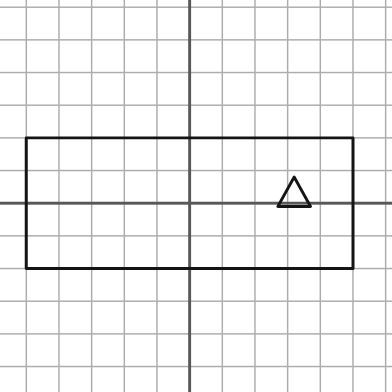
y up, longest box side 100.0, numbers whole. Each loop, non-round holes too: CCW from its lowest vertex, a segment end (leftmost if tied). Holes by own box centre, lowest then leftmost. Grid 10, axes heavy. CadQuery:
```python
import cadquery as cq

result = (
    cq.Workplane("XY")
    .moveTo(-50.0, -20.0)
    .lineTo(50.0, -20.0)
    .lineTo(50.0, 20.0)
    .lineTo(-50.0, 20.0)
    .close()
    .moveTo(27.0, -1.0)
    .lineTo(37.0, -1.0)
    .lineTo(32.0, 8.0)
    .close()
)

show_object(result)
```